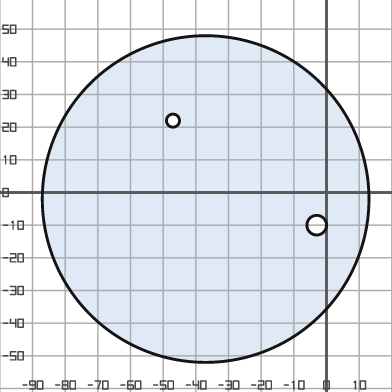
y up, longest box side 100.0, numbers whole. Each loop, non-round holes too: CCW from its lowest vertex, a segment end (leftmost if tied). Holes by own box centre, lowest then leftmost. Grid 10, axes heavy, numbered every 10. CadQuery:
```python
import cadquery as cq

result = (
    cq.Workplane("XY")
    .moveTo(-37.0, -2.0)
    .circle(50.0)
    .moveTo(-3.0, -10.0)
    .circle(3.0)
    .moveTo(-47.0, 22.0)
    .circle(2.0)
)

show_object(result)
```